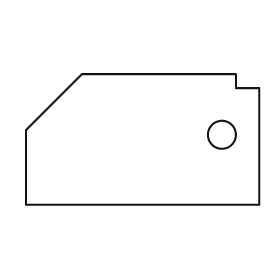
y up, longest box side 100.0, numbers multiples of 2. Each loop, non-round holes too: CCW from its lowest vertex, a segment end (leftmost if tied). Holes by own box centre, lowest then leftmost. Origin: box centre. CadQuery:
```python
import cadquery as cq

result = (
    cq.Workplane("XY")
    .moveTo(-50.0, -28.0)
    .lineTo(50.0, -28.0)
    .lineTo(50.0, 22.0)
    .lineTo(40.0, 22.0)
    .lineTo(40.0, 28.0)
    .lineTo(-26.0, 28.0)
    .lineTo(-50.0, 4.0)
    .close()
    .moveTo(34.0, 2.0)
    .circle(6.0)
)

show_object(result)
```